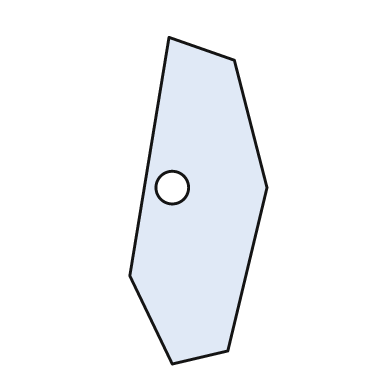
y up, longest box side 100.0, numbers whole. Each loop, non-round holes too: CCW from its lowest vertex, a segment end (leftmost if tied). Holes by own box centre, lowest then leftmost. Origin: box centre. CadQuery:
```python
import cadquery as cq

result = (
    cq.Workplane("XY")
    .moveTo(-8.0, -50.0)
    .lineTo(9.0, -46.0)
    .lineTo(21.0, 4.0)
    .lineTo(11.0, 43.0)
    .lineTo(-9.0, 50.0)
    .lineTo(-21.0, -23.0)
    .close()
    .moveTo(-8.0, 4.0)
    .circle(5.0)
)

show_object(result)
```